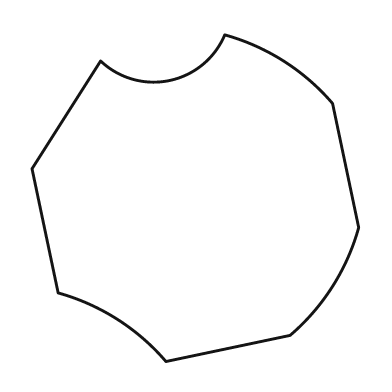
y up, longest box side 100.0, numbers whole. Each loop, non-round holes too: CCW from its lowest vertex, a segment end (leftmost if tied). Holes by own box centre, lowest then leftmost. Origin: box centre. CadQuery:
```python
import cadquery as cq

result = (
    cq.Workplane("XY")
    .moveTo(-9.0, -50.0)
    .lineTo(29.0, -42.0)
    .threePointArc((42.0, -27.0), (50.0, -9.0))
    .lineTo(42.0, 29.0)
    .threePointArc((27.0, 42.0), (9.0, 50.0))
    .threePointArc((-8.0, 36.0), (-29.0, 42.0))
    .lineTo(-50.0, 9.0)
    .lineTo(-42.0, -29.0)
    .threePointArc((-24.0, -37.0), (-9.0, -50.0))
    .close()
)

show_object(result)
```